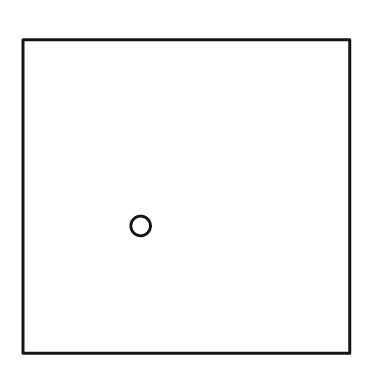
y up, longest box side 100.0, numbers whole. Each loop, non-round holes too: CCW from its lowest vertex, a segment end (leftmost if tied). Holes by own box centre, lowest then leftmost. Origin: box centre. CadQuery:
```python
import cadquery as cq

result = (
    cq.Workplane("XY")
    .moveTo(-50.0, -48.0)
    .lineTo(50.0, -48.0)
    .lineTo(50.0, 48.0)
    .lineTo(-50.0, 48.0)
    .close()
    .moveTo(-14.0, -9.0)
    .circle(3.0)
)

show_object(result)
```